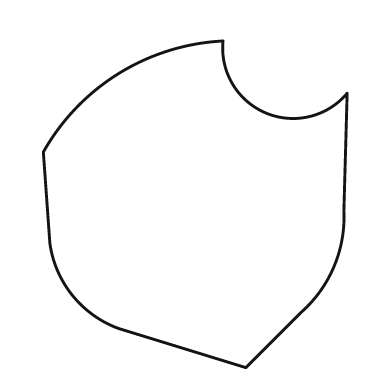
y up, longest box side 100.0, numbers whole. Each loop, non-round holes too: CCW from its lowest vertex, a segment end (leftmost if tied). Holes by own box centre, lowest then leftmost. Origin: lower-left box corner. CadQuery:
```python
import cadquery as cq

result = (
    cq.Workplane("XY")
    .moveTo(62.0, 0.0)
    .lineTo(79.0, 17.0)
    .threePointArc((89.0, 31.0), (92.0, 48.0))
    .lineTo(93.0, 84.0)
    .threePointArc((68.0, 78.0), (55.0, 100.0))
    .threePointArc((23.0, 90.0), (0.0, 66.0))
    .lineTo(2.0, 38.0)
    .threePointArc((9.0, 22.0), (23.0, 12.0))
    .close()
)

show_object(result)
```